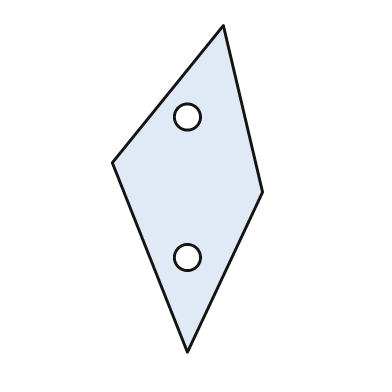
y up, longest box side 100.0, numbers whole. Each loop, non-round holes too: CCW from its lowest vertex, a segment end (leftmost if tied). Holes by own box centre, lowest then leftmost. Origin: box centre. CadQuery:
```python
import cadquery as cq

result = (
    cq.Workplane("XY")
    .moveTo(0.0, -50.0)
    .lineTo(23.0, -1.0)
    .lineTo(11.0, 50.0)
    .lineTo(-23.0, 8.0)
    .close()
    .moveTo(0.0, -21.0)
    .circle(4.0)
    .moveTo(0.0, 22.0)
    .circle(4.0)
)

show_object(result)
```